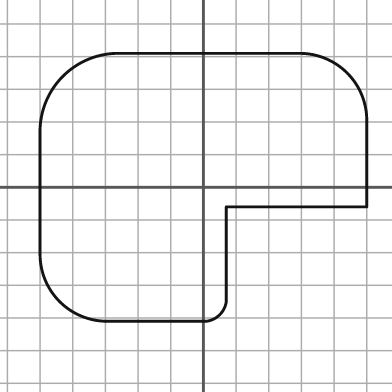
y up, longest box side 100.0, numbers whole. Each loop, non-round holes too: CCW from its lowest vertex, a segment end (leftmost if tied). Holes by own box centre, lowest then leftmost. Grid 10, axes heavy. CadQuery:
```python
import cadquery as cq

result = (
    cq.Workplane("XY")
    .moveTo(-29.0, -41.0)
    .lineTo(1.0, -41.0)
    .threePointArc((5.0, -39.0), (7.0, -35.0))
    .lineTo(7.0, -6.0)
    .lineTo(50.0, -6.0)
    .lineTo(50.0, 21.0)
    .threePointArc((44.0, 35.0), (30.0, 41.0))
    .lineTo(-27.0, 41.0)
    .threePointArc((-43.0, 34.0), (-50.0, 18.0))
    .lineTo(-50.0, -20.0)
    .threePointArc((-44.0, -35.0), (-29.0, -41.0))
    .close()
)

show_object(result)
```